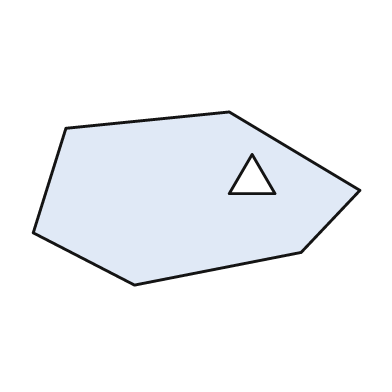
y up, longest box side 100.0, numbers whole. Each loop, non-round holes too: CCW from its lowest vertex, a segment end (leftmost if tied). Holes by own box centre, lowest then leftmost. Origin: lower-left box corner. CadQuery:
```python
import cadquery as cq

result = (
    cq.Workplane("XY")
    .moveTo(31.0, 0.0)
    .lineTo(82.0, 10.0)
    .lineTo(100.0, 29.0)
    .lineTo(60.0, 53.0)
    .lineTo(10.0, 48.0)
    .lineTo(0.0, 16.0)
    .close()
    .moveTo(60.0, 28.0)
    .lineTo(74.0, 28.0)
    .lineTo(67.0, 40.0)
    .close()
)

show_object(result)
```